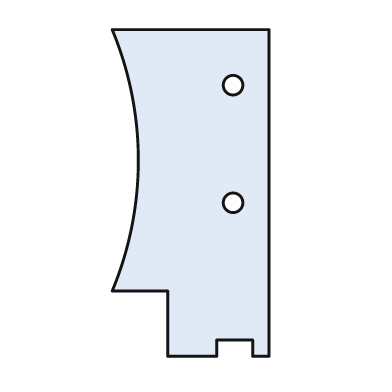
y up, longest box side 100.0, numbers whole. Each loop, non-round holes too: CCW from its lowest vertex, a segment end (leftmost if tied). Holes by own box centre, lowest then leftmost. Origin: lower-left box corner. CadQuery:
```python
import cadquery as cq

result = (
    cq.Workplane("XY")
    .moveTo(17.0, 0.0)
    .lineTo(32.0, 0.0)
    .lineTo(32.0, 5.0)
    .lineTo(43.0, 5.0)
    .lineTo(43.0, 0.0)
    .lineTo(48.0, 0.0)
    .lineTo(48.0, 100.0)
    .lineTo(0.0, 100.0)
    .threePointArc((8.0, 60.0), (0.0, 20.0))
    .lineTo(17.0, 20.0)
    .close()
    .moveTo(37.0, 47.0)
    .circle(3.0)
    .moveTo(37.0, 83.0)
    .circle(3.0)
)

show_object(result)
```